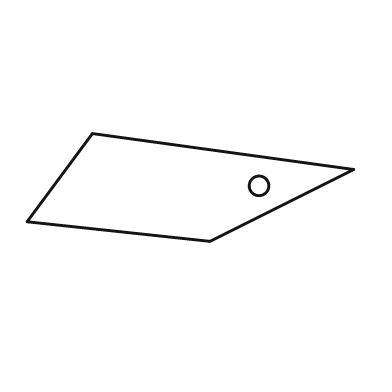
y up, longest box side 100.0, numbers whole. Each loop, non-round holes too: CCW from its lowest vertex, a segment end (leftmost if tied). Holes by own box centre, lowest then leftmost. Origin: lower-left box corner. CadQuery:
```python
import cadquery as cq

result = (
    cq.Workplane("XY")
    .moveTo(56.0, 0.0)
    .lineTo(100.0, 22.0)
    .lineTo(20.0, 33.0)
    .lineTo(0.0, 6.0)
    .close()
    .moveTo(71.0, 17.0)
    .circle(3.0)
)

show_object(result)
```